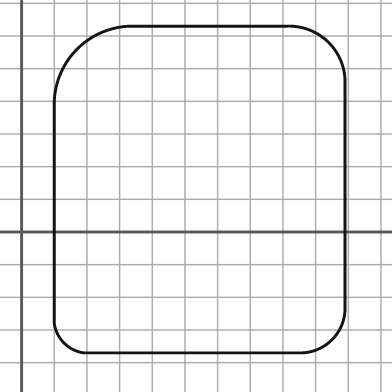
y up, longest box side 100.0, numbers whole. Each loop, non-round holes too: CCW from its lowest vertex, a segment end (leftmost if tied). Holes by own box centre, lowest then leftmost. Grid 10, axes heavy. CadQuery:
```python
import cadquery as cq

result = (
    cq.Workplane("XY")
    .moveTo(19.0, -37.0)
    .lineTo(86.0, -37.0)
    .threePointArc((95.0, -33.0), (99.0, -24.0))
    .lineTo(99.0, 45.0)
    .threePointArc((94.0, 58.0), (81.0, 63.0))
    .lineTo(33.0, 63.0)
    .threePointArc((17.0, 56.0), (10.0, 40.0))
    .lineTo(10.0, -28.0)
    .threePointArc((13.0, -34.0), (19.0, -37.0))
    .close()
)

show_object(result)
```